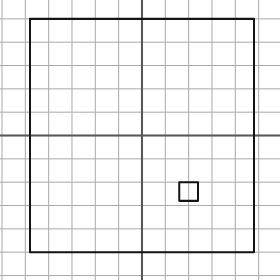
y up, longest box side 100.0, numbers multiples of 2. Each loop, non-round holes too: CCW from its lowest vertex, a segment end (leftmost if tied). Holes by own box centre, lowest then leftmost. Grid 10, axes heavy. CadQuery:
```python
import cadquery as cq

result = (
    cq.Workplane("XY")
    .moveTo(-48.0, -50.0)
    .lineTo(48.0, -50.0)
    .lineTo(48.0, 50.0)
    .lineTo(-48.0, 50.0)
    .close()
    .moveTo(16.0, -28.0)
    .lineTo(24.0, -28.0)
    .lineTo(24.0, -20.0)
    .lineTo(16.0, -20.0)
    .close()
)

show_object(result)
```